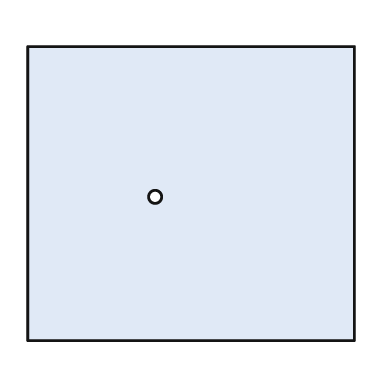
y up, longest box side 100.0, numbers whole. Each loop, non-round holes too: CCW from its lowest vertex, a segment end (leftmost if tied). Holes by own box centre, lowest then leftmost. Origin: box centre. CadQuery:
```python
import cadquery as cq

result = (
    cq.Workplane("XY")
    .moveTo(-50.0, -45.0)
    .lineTo(50.0, -45.0)
    .lineTo(50.0, 45.0)
    .lineTo(-50.0, 45.0)
    .close()
    .moveTo(-11.0, -1.0)
    .circle(2.0)
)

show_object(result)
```